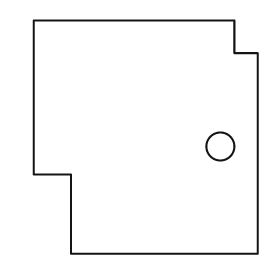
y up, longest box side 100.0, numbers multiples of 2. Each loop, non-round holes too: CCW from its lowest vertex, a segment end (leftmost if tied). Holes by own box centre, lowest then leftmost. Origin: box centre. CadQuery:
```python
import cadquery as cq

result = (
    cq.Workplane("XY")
    .moveTo(-32.0, -50.0)
    .lineTo(48.0, -50.0)
    .lineTo(48.0, 36.0)
    .lineTo(38.0, 36.0)
    .lineTo(38.0, 50.0)
    .lineTo(-48.0, 50.0)
    .lineTo(-48.0, -16.0)
    .lineTo(-32.0, -16.0)
    .close()
    .moveTo(32.0, -4.0)
    .circle(6.0)
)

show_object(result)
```